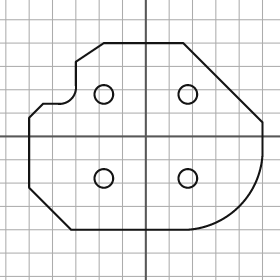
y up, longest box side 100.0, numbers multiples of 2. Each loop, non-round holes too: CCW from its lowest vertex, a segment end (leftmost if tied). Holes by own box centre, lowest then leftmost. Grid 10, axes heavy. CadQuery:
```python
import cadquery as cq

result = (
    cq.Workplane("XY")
    .moveTo(-32.0, -40.0)
    .lineTo(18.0, -40.0)
    .threePointArc((40.0, -30.0), (50.0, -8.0))
    .lineTo(50.0, 6.0)
    .lineTo(16.0, 40.0)
    .lineTo(-18.0, 40.0)
    .lineTo(-30.0, 32.0)
    .lineTo(-30.0, 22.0)
    .threePointArc((-32.0, 16.0), (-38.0, 14.0))
    .lineTo(-44.0, 14.0)
    .lineTo(-50.0, 8.0)
    .lineTo(-50.0, -22.0)
    .close()
    .moveTo(-18.0, -18.0)
    .circle(4.0)
    .moveTo(18.0, -18.0)
    .circle(4.0)
    .moveTo(-18.0, 18.0)
    .circle(4.0)
    .moveTo(18.0, 18.0)
    .circle(4.0)
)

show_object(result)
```